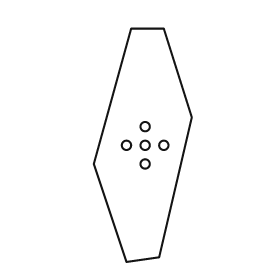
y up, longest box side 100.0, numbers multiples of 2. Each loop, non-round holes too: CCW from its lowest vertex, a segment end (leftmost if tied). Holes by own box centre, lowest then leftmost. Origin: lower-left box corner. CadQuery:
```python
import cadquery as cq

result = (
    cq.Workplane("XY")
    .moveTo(14.0, 0.0)
    .lineTo(28.0, 2.0)
    .lineTo(42.0, 62.0)
    .lineTo(30.0, 100.0)
    .lineTo(16.0, 100.0)
    .lineTo(0.0, 42.0)
    .close()
    .moveTo(22.0, 42.0)
    .circle(2.0)
    .moveTo(14.0, 50.0)
    .circle(2.0)
    .moveTo(22.0, 50.0)
    .circle(2.0)
    .moveTo(30.0, 50.0)
    .circle(2.0)
    .moveTo(22.0, 58.0)
    .circle(2.0)
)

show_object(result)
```